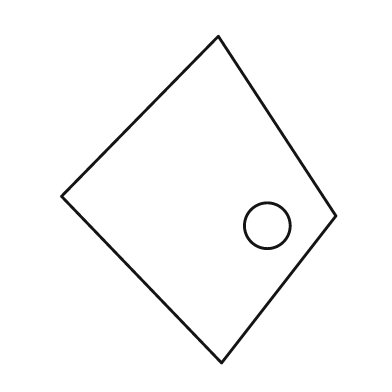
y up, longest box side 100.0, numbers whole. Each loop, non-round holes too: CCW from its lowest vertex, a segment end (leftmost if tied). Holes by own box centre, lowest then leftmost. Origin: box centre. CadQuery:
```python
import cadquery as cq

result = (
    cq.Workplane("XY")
    .moveTo(7.0, -50.0)
    .lineTo(42.0, -5.0)
    .lineTo(6.0, 50.0)
    .lineTo(-42.0, 1.0)
    .close()
    .moveTo(21.0, -8.0)
    .circle(7.0)
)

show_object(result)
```